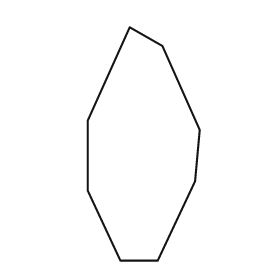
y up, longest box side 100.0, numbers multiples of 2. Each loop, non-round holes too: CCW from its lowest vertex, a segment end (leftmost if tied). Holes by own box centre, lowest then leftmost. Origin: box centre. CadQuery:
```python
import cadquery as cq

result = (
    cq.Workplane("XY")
    .moveTo(-10.0, -50.0)
    .lineTo(6.0, -50.0)
    .lineTo(22.0, -16.0)
    .lineTo(24.0, 6.0)
    .lineTo(8.0, 42.0)
    .lineTo(-6.0, 50.0)
    .lineTo(-24.0, 10.0)
    .lineTo(-24.0, -20.0)
    .close()
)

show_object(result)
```